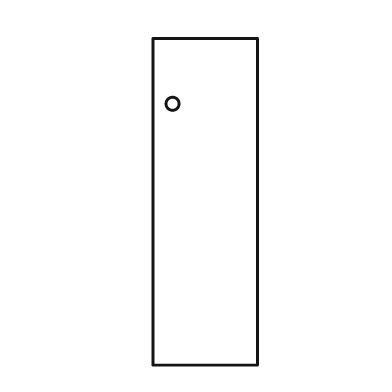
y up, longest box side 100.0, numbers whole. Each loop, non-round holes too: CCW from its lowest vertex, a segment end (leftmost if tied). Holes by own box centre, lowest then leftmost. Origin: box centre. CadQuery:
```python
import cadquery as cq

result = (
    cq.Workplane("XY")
    .moveTo(-16.0, -50.0)
    .lineTo(16.0, -50.0)
    .lineTo(16.0, 50.0)
    .lineTo(-16.0, 50.0)
    .close()
    .moveTo(-10.0, 30.0)
    .circle(2.0)
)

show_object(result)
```